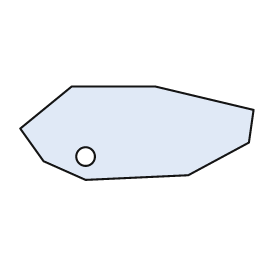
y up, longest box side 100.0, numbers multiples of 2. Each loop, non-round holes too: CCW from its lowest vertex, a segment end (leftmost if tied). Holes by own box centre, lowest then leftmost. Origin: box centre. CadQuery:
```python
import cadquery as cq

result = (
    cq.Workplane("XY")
    .moveTo(-22.0, -20.0)
    .lineTo(22.0, -18.0)
    .lineTo(48.0, -4.0)
    .lineTo(50.0, 10.0)
    .lineTo(8.0, 20.0)
    .lineTo(-28.0, 20.0)
    .lineTo(-50.0, 2.0)
    .lineTo(-40.0, -12.0)
    .close()
    .moveTo(-22.0, -10.0)
    .circle(4.0)
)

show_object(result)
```